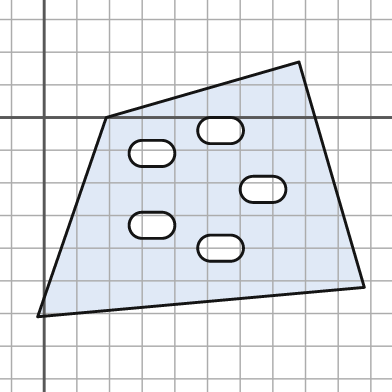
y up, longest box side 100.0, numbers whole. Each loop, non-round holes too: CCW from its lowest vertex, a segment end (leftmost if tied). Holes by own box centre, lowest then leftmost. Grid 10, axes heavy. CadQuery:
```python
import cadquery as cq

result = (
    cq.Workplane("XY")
    .moveTo(-2.0, -61.0)
    .lineTo(98.0, -52.0)
    .lineTo(78.0, 17.0)
    .lineTo(19.0, 0.0)
    .close()
    .moveTo(51.0, -44.0)
    .lineTo(57.0, -44.0)
    .threePointArc((61.0, -40.0), (57.0, -36.0))
    .lineTo(51.0, -36.0)
    .threePointArc((47.0, -40.0), (51.0, -44.0))
    .close()
    .moveTo(30.0, -37.0)
    .lineTo(36.0, -37.0)
    .threePointArc((40.0, -33.0), (36.0, -29.0))
    .lineTo(30.0, -29.0)
    .threePointArc((26.0, -33.0), (30.0, -37.0))
    .close()
    .moveTo(64.0, -26.0)
    .lineTo(70.0, -26.0)
    .threePointArc((74.0, -22.0), (70.0, -18.0))
    .lineTo(64.0, -18.0)
    .threePointArc((60.0, -22.0), (64.0, -26.0))
    .close()
    .moveTo(30.0, -15.0)
    .lineTo(36.0, -15.0)
    .threePointArc((40.0, -11.0), (36.0, -7.0))
    .lineTo(30.0, -7.0)
    .threePointArc((26.0, -11.0), (30.0, -15.0))
    .close()
    .moveTo(51.0, -8.0)
    .lineTo(57.0, -8.0)
    .threePointArc((61.0, -4.0), (57.0, 0.0))
    .lineTo(51.0, 0.0)
    .threePointArc((47.0, -4.0), (51.0, -8.0))
    .close()
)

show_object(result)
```